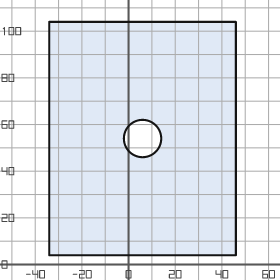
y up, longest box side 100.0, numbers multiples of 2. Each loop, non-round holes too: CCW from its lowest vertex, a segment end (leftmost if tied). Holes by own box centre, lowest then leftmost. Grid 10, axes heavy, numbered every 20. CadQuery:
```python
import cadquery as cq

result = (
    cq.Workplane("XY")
    .moveTo(-34.0, 4.0)
    .lineTo(46.0, 4.0)
    .lineTo(46.0, 104.0)
    .lineTo(-34.0, 104.0)
    .close()
    .moveTo(6.0, 54.0)
    .circle(8.0)
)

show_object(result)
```